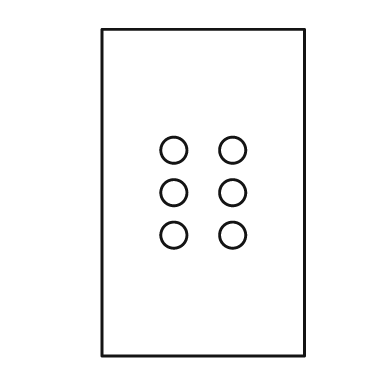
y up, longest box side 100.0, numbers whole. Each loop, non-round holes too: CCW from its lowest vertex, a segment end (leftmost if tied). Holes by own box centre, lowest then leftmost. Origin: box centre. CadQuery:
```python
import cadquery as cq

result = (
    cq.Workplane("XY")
    .moveTo(-31.0, -50.0)
    .lineTo(31.0, -50.0)
    .lineTo(31.0, 50.0)
    .lineTo(-31.0, 50.0)
    .close()
    .moveTo(-9.0, -13.0)
    .circle(4.0)
    .moveTo(9.0, -13.0)
    .circle(4.0)
    .moveTo(-9.0, 0.0)
    .circle(4.0)
    .moveTo(9.0, 0.0)
    .circle(4.0)
    .moveTo(-9.0, 13.0)
    .circle(4.0)
    .moveTo(9.0, 13.0)
    .circle(4.0)
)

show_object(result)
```